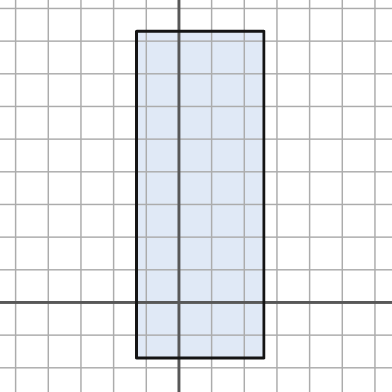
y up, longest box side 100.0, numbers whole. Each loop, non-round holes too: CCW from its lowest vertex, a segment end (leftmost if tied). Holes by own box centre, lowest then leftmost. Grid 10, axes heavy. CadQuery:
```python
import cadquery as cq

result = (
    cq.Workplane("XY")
    .moveTo(-13.0, -17.0)
    .lineTo(26.0, -17.0)
    .lineTo(26.0, 83.0)
    .lineTo(-13.0, 83.0)
    .close()
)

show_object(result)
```